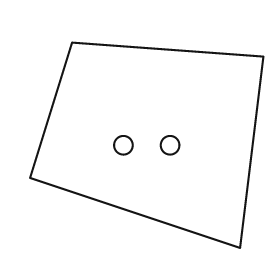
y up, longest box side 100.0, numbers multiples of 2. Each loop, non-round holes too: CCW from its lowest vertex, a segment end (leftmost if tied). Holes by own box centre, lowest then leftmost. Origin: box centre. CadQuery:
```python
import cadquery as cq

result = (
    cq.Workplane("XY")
    .moveTo(40.0, -44.0)
    .lineTo(50.0, 38.0)
    .lineTo(-32.0, 44.0)
    .lineTo(-50.0, -14.0)
    .close()
    .moveTo(-10.0, 0.0)
    .circle(4.0)
    .moveTo(10.0, 0.0)
    .circle(4.0)
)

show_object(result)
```